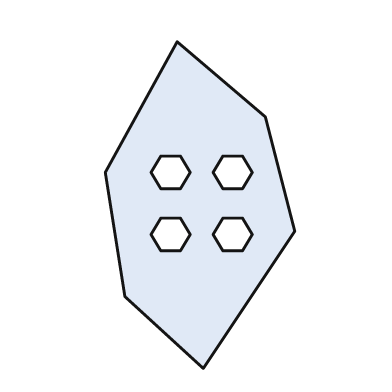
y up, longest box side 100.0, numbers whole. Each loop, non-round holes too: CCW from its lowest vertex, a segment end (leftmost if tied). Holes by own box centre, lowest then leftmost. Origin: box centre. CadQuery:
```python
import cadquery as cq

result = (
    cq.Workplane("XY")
    .moveTo(1.0, -50.0)
    .lineTo(29.0, -8.0)
    .lineTo(20.0, 27.0)
    .lineTo(-7.0, 50.0)
    .lineTo(-29.0, 10.0)
    .lineTo(-23.0, -28.0)
    .close()
    .moveTo(-12.0, -14.0)
    .lineTo(-6.0, -14.0)
    .lineTo(-3.0, -9.0)
    .lineTo(-6.0, -4.0)
    .lineTo(-12.0, -4.0)
    .lineTo(-15.0, -9.0)
    .close()
    .moveTo(7.0, -14.0)
    .lineTo(13.0, -14.0)
    .lineTo(16.0, -9.0)
    .lineTo(13.0, -4.0)
    .lineTo(7.0, -4.0)
    .lineTo(4.0, -9.0)
    .close()
    .moveTo(-12.0, 5.0)
    .lineTo(-6.0, 5.0)
    .lineTo(-3.0, 10.0)
    .lineTo(-6.0, 15.0)
    .lineTo(-12.0, 15.0)
    .lineTo(-15.0, 10.0)
    .close()
    .moveTo(7.0, 5.0)
    .lineTo(13.0, 5.0)
    .lineTo(16.0, 10.0)
    .lineTo(13.0, 15.0)
    .lineTo(7.0, 15.0)
    .lineTo(4.0, 10.0)
    .close()
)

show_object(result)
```